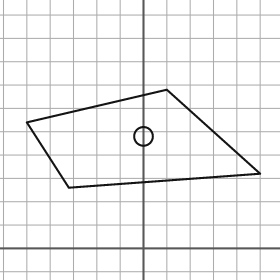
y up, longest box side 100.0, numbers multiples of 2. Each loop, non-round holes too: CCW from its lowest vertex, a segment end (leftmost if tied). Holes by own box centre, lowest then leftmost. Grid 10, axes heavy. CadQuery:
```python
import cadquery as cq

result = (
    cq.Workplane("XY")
    .moveTo(-32.0, 26.0)
    .lineTo(50.0, 32.0)
    .lineTo(10.0, 68.0)
    .lineTo(-50.0, 54.0)
    .close()
    .moveTo(0.0, 48.0)
    .circle(4.0)
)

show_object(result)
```